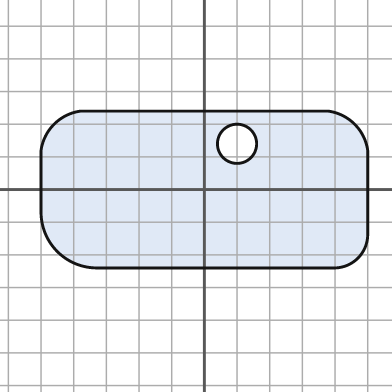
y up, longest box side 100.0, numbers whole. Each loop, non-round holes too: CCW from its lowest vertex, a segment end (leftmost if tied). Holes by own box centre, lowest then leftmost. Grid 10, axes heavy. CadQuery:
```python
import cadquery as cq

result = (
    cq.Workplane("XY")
    .moveTo(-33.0, -24.0)
    .lineTo(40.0, -24.0)
    .threePointArc((47.0, -21.0), (50.0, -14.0))
    .lineTo(50.0, 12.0)
    .threePointArc((46.0, 20.0), (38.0, 24.0))
    .lineTo(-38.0, 24.0)
    .threePointArc((-46.0, 20.0), (-50.0, 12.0))
    .lineTo(-50.0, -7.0)
    .threePointArc((-45.0, -19.0), (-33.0, -24.0))
    .close()
    .moveTo(10.0, 14.0)
    .circle(6.0)
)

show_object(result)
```